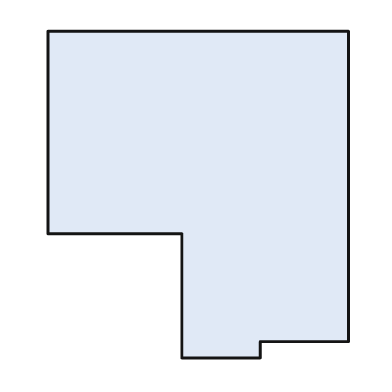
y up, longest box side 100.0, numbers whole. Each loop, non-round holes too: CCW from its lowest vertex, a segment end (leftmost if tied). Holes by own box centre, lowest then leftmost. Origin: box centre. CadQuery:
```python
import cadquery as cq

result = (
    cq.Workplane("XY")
    .moveTo(-5.0, -50.0)
    .lineTo(19.0, -50.0)
    .lineTo(19.0, -45.0)
    .lineTo(46.0, -45.0)
    .lineTo(46.0, 50.0)
    .lineTo(-46.0, 50.0)
    .lineTo(-46.0, -12.0)
    .lineTo(-5.0, -12.0)
    .close()
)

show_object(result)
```